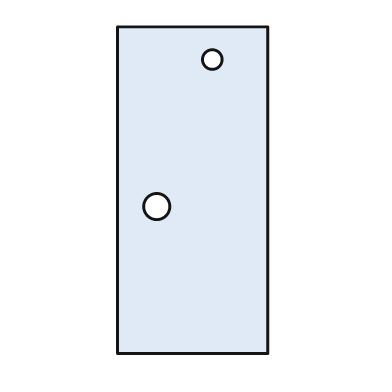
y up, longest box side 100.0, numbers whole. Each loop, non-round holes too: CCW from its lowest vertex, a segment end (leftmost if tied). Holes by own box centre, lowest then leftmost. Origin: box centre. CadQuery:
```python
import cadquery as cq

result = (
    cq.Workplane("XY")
    .moveTo(-23.0, -50.0)
    .lineTo(23.0, -50.0)
    .lineTo(23.0, 50.0)
    .lineTo(-23.0, 50.0)
    .close()
    .moveTo(-11.0, -5.0)
    .circle(4.0)
    .moveTo(6.0, 40.0)
    .circle(3.0)
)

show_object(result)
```